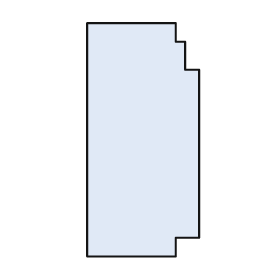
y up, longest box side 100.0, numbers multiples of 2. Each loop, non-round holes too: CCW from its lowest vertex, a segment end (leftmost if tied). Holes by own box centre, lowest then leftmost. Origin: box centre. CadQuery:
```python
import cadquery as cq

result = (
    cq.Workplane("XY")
    .moveTo(-24.0, -50.0)
    .lineTo(14.0, -50.0)
    .lineTo(14.0, -42.0)
    .lineTo(24.0, -42.0)
    .lineTo(24.0, 30.0)
    .lineTo(18.0, 30.0)
    .lineTo(18.0, 42.0)
    .lineTo(14.0, 42.0)
    .lineTo(14.0, 50.0)
    .lineTo(-24.0, 50.0)
    .close()
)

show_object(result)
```